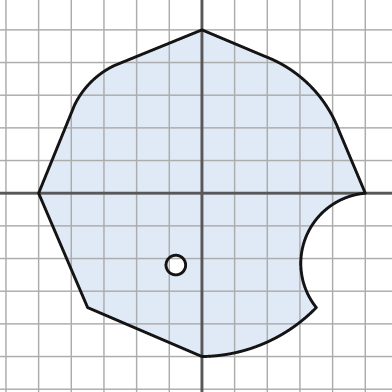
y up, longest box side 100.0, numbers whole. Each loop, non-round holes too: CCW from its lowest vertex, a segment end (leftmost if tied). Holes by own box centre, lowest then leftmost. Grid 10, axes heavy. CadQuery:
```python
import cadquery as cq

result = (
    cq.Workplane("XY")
    .moveTo(0.0, -50.0)
    .threePointArc((19.0, -46.0), (35.0, -35.0))
    .threePointArc((32.0, -13.0), (50.0, 0.0))
    .lineTo(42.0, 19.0)
    .threePointArc((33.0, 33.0), (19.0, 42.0))
    .lineTo(0.0, 50.0)
    .lineTo(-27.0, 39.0)
    .threePointArc((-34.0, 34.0), (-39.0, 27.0))
    .lineTo(-50.0, 0.0)
    .lineTo(-35.0, -35.0)
    .close()
    .moveTo(-8.0, -22.0)
    .circle(3.0)
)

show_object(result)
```